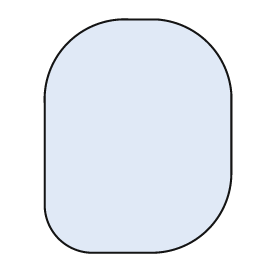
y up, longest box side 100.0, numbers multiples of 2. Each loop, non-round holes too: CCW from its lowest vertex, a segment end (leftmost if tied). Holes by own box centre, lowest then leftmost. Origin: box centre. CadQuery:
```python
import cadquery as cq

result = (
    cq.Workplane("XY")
    .moveTo(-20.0, -50.0)
    .lineTo(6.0, -50.0)
    .threePointArc((30.0, -40.0), (40.0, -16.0))
    .lineTo(40.0, 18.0)
    .threePointArc((30.0, 40.0), (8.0, 50.0))
    .lineTo(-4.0, 50.0)
    .threePointArc((-30.0, 40.0), (-40.0, 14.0))
    .lineTo(-40.0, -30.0)
    .threePointArc((-34.0, -44.0), (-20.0, -50.0))
    .close()
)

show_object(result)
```